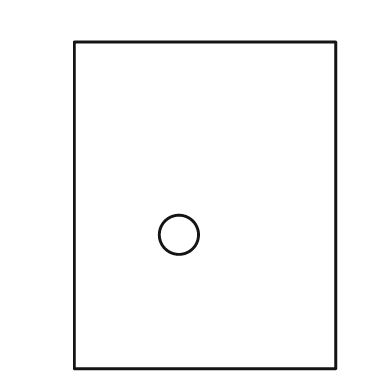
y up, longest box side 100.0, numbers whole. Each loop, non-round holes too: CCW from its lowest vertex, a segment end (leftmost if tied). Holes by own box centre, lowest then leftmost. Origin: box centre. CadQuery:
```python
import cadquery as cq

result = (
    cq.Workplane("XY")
    .moveTo(-40.0, -50.0)
    .lineTo(40.0, -50.0)
    .lineTo(40.0, 50.0)
    .lineTo(-40.0, 50.0)
    .close()
    .moveTo(-8.0, -9.0)
    .circle(6.0)
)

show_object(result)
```